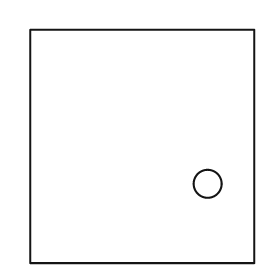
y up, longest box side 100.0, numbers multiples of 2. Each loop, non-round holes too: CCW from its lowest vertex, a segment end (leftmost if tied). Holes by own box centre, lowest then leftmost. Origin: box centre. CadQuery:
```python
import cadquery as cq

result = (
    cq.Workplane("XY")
    .moveTo(-48.0, -50.0)
    .lineTo(48.0, -50.0)
    .lineTo(48.0, 50.0)
    .lineTo(-48.0, 50.0)
    .close()
    .moveTo(28.0, -16.0)
    .circle(6.0)
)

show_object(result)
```